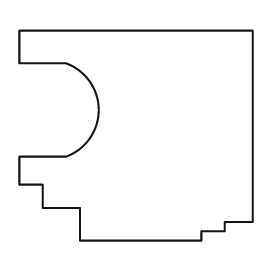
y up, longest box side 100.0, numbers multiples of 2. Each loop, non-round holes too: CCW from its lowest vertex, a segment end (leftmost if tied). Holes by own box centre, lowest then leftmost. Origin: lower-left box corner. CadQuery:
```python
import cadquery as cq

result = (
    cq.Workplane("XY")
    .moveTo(26.0, 0.0)
    .lineTo(78.0, 0.0)
    .lineTo(78.0, 4.0)
    .lineTo(88.0, 4.0)
    .lineTo(88.0, 8.0)
    .lineTo(100.0, 8.0)
    .lineTo(100.0, 90.0)
    .lineTo(0.0, 90.0)
    .lineTo(0.0, 76.0)
    .lineTo(20.0, 76.0)
    .threePointArc((34.0, 56.0), (20.0, 36.0))
    .lineTo(0.0, 36.0)
    .lineTo(0.0, 24.0)
    .lineTo(10.0, 24.0)
    .lineTo(10.0, 14.0)
    .lineTo(26.0, 14.0)
    .close()
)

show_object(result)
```